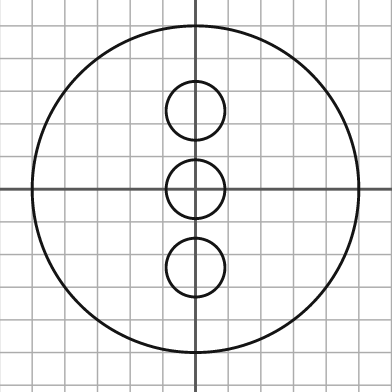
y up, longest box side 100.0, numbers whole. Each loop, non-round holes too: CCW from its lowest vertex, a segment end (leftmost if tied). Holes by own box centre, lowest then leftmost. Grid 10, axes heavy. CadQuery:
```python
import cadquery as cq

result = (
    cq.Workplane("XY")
    .moveTo(0.0, 0.0)
    .circle(50.0)
    .moveTo(0.0, -24.0)
    .circle(9.0)
    .moveTo(0.0, 0.0)
    .circle(9.0)
    .moveTo(0.0, 24.0)
    .circle(9.0)
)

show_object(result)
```